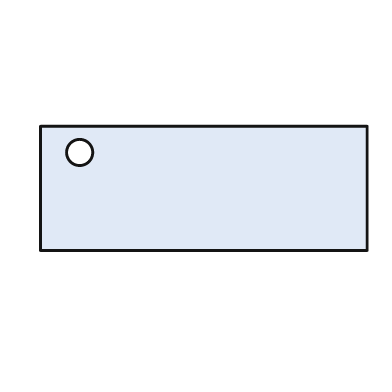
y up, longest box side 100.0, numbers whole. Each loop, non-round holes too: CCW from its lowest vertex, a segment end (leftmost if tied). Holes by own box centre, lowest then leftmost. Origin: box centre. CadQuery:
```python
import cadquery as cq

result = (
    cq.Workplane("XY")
    .moveTo(-50.0, -19.0)
    .lineTo(50.0, -19.0)
    .lineTo(50.0, 19.0)
    .lineTo(-50.0, 19.0)
    .close()
    .moveTo(-38.0, 11.0)
    .circle(4.0)
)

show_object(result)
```